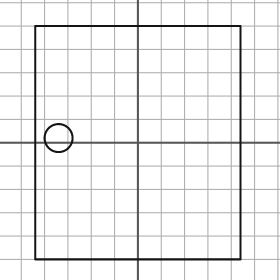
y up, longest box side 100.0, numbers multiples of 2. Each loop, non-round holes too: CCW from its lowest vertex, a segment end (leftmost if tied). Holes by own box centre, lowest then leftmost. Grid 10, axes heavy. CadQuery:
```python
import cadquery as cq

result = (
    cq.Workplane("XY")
    .moveTo(-44.0, -50.0)
    .lineTo(44.0, -50.0)
    .lineTo(44.0, 50.0)
    .lineTo(-44.0, 50.0)
    .close()
    .moveTo(-34.0, 2.0)
    .circle(6.0)
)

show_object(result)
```